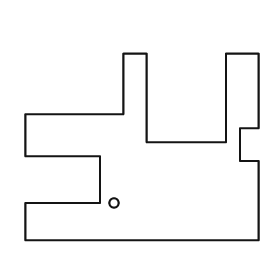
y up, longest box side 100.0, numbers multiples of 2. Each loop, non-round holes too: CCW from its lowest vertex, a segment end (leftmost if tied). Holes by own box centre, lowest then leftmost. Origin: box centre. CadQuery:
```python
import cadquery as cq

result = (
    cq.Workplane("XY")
    .moveTo(-50.0, -40.0)
    .lineTo(50.0, -40.0)
    .lineTo(50.0, -6.0)
    .lineTo(42.0, -6.0)
    .lineTo(42.0, 8.0)
    .lineTo(50.0, 8.0)
    .lineTo(50.0, 40.0)
    .lineTo(36.0, 40.0)
    .lineTo(36.0, 2.0)
    .lineTo(2.0, 2.0)
    .lineTo(2.0, 40.0)
    .lineTo(-8.0, 40.0)
    .lineTo(-8.0, 14.0)
    .lineTo(-50.0, 14.0)
    .lineTo(-50.0, -4.0)
    .lineTo(-18.0, -4.0)
    .lineTo(-18.0, -24.0)
    .lineTo(-50.0, -24.0)
    .close()
    .moveTo(-12.0, -24.0)
    .circle(2.0)
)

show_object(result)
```